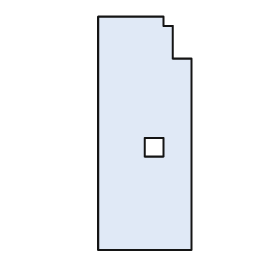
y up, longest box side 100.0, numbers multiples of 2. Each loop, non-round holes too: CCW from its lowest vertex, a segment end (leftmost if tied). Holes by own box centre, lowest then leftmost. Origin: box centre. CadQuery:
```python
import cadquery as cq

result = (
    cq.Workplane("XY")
    .moveTo(-20.0, -50.0)
    .lineTo(20.0, -50.0)
    .lineTo(20.0, 32.0)
    .lineTo(12.0, 32.0)
    .lineTo(12.0, 46.0)
    .lineTo(8.0, 46.0)
    .lineTo(8.0, 50.0)
    .lineTo(-20.0, 50.0)
    .close()
    .moveTo(0.0, -10.0)
    .lineTo(8.0, -10.0)
    .lineTo(8.0, -2.0)
    .lineTo(0.0, -2.0)
    .close()
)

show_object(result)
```